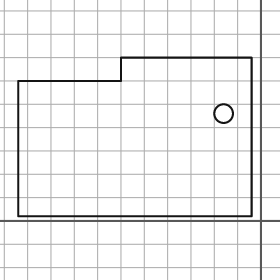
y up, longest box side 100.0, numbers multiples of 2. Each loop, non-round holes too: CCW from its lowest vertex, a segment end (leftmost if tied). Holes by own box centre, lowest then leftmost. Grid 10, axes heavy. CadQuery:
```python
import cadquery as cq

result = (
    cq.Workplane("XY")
    .moveTo(-104.0, 2.0)
    .lineTo(-4.0, 2.0)
    .lineTo(-4.0, 70.0)
    .lineTo(-60.0, 70.0)
    .lineTo(-60.0, 60.0)
    .lineTo(-104.0, 60.0)
    .close()
    .moveTo(-16.0, 46.0)
    .circle(4.0)
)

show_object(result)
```